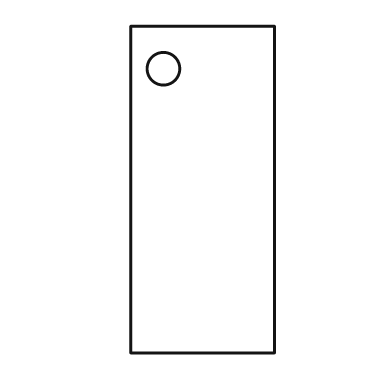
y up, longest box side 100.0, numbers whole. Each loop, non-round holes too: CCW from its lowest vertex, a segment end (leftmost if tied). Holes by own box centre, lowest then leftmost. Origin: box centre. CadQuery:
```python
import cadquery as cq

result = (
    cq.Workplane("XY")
    .moveTo(-22.0, -50.0)
    .lineTo(22.0, -50.0)
    .lineTo(22.0, 50.0)
    .lineTo(-22.0, 50.0)
    .close()
    .moveTo(-12.0, 37.0)
    .circle(5.0)
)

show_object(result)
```